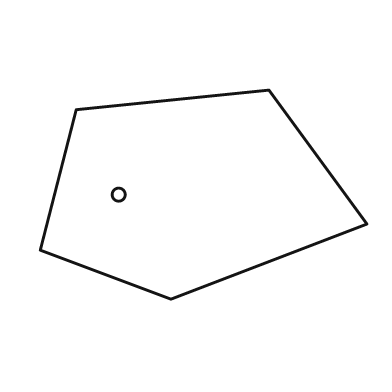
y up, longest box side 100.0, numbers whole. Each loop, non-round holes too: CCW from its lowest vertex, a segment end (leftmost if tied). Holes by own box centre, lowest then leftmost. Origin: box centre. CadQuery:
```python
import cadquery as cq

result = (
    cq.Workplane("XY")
    .moveTo(-10.0, -32.0)
    .lineTo(50.0, -9.0)
    .lineTo(20.0, 32.0)
    .lineTo(-39.0, 26.0)
    .lineTo(-50.0, -17.0)
    .close()
    .moveTo(-26.0, 0.0)
    .circle(2.0)
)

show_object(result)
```